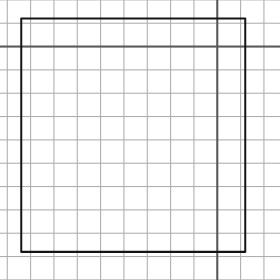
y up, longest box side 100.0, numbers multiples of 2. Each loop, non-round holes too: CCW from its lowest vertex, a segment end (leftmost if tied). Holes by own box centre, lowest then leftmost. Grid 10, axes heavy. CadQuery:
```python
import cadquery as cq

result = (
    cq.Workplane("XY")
    .moveTo(-84.0, -88.0)
    .lineTo(12.0, -88.0)
    .lineTo(12.0, 12.0)
    .lineTo(-84.0, 12.0)
    .close()
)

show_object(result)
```